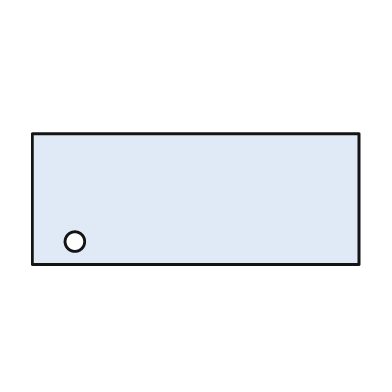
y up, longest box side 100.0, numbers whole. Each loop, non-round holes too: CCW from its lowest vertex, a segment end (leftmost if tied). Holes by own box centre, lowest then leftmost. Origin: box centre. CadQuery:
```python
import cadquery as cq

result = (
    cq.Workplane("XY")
    .moveTo(-50.0, -20.0)
    .lineTo(50.0, -20.0)
    .lineTo(50.0, 20.0)
    .lineTo(-50.0, 20.0)
    .close()
    .moveTo(-37.0, -13.0)
    .circle(3.0)
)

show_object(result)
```